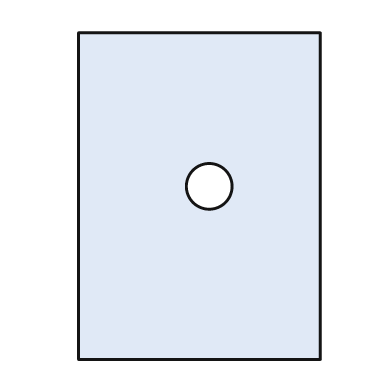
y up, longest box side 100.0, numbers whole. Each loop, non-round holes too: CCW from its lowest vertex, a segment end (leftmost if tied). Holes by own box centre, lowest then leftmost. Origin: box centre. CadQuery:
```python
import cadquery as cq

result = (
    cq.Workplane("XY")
    .moveTo(-37.0, -50.0)
    .lineTo(37.0, -50.0)
    .lineTo(37.0, 50.0)
    .lineTo(-37.0, 50.0)
    .close()
    .moveTo(3.0, 3.0)
    .circle(7.0)
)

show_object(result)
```